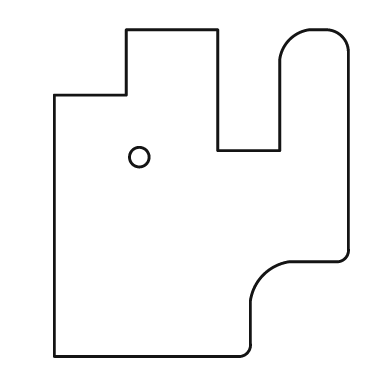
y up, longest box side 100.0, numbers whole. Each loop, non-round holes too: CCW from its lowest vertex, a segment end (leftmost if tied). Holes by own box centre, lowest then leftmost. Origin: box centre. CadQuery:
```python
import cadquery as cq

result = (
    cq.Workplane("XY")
    .moveTo(-45.0, -50.0)
    .lineTo(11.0, -50.0)
    .threePointArc((14.0, -49.0), (15.0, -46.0))
    .lineTo(15.0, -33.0)
    .threePointArc((19.0, -25.0), (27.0, -21.0))
    .lineTo(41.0, -21.0)
    .threePointArc((44.0, -20.0), (45.0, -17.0))
    .lineTo(45.0, 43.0)
    .threePointArc((43.0, 48.0), (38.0, 50.0))
    .lineTo(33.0, 50.0)
    .threePointArc((27.0, 47.0), (24.0, 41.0))
    .lineTo(24.0, 13.0)
    .lineTo(5.0, 13.0)
    .lineTo(5.0, 50.0)
    .lineTo(-23.0, 50.0)
    .lineTo(-23.0, 30.0)
    .lineTo(-45.0, 30.0)
    .close()
    .moveTo(-19.0, 11.0)
    .circle(3.0)
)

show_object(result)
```